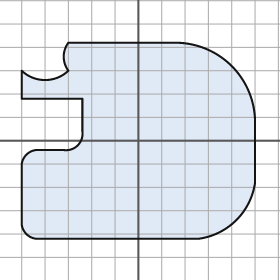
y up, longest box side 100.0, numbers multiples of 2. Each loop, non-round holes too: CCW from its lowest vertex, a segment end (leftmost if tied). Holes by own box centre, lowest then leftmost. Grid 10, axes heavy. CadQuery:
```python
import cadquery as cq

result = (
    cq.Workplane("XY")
    .moveTo(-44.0, -42.0)
    .lineTo(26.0, -42.0)
    .threePointArc((42.0, -34.0), (50.0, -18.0))
    .lineTo(50.0, 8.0)
    .threePointArc((40.0, 32.0), (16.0, 42.0))
    .lineTo(-30.0, 42.0)
    .threePointArc((-32.0, 36.0), (-30.0, 30.0))
    .threePointArc((-40.0, 26.0), (-50.0, 30.0))
    .lineTo(-50.0, 18.0)
    .lineTo(-24.0, 18.0)
    .lineTo(-24.0, 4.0)
    .threePointArc((-26.0, -2.0), (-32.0, -4.0))
    .lineTo(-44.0, -4.0)
    .threePointArc((-48.0, -6.0), (-50.0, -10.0))
    .lineTo(-50.0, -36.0)
    .threePointArc((-48.0, -40.0), (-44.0, -42.0))
    .close()
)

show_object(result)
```